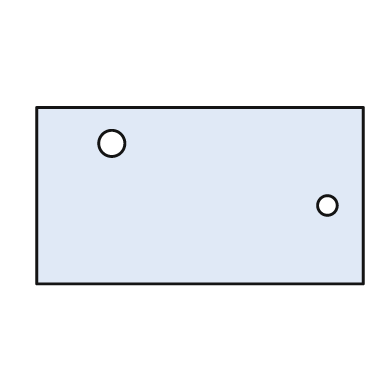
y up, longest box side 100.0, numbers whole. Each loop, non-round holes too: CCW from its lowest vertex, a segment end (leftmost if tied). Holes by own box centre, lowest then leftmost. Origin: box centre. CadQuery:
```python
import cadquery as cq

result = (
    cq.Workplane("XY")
    .moveTo(-50.0, -27.0)
    .lineTo(50.0, -27.0)
    .lineTo(50.0, 27.0)
    .lineTo(-50.0, 27.0)
    .close()
    .moveTo(39.0, -3.0)
    .circle(3.0)
    .moveTo(-27.0, 16.0)
    .circle(4.0)
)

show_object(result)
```